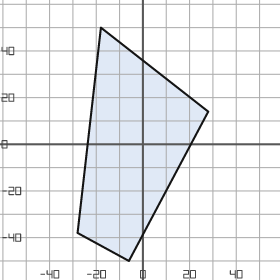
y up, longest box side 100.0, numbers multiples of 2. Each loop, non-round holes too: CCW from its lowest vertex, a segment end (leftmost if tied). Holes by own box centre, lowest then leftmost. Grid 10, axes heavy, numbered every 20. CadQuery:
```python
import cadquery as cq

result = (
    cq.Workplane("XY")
    .moveTo(-6.0, -50.0)
    .lineTo(28.0, 14.0)
    .lineTo(-18.0, 50.0)
    .lineTo(-28.0, -38.0)
    .close()
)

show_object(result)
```